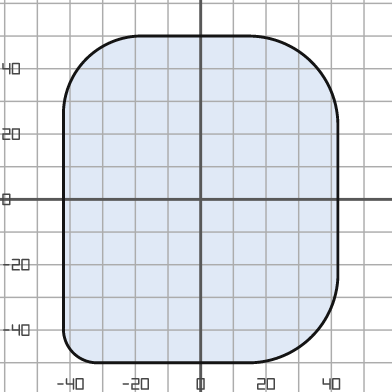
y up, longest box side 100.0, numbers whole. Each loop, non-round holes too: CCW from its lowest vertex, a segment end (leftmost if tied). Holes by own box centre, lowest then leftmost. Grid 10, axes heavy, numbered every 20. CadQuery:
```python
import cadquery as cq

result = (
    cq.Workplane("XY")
    .moveTo(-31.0, -50.0)
    .lineTo(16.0, -50.0)
    .threePointArc((34.0, -42.0), (42.0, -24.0))
    .lineTo(42.0, 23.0)
    .threePointArc((34.0, 42.0), (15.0, 50.0))
    .lineTo(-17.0, 50.0)
    .threePointArc((-35.0, 43.0), (-42.0, 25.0))
    .lineTo(-42.0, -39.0)
    .threePointArc((-39.0, -47.0), (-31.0, -50.0))
    .close()
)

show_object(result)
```